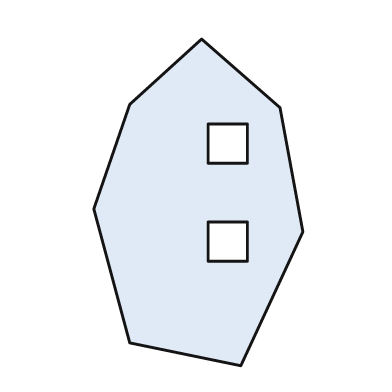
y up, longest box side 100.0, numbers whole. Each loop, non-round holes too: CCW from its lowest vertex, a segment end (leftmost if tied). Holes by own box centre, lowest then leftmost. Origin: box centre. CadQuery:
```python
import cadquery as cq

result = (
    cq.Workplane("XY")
    .moveTo(13.0, -50.0)
    .lineTo(32.0, -9.0)
    .lineTo(25.0, 29.0)
    .lineTo(1.0, 50.0)
    .lineTo(-21.0, 30.0)
    .lineTo(-32.0, -2.0)
    .lineTo(-21.0, -43.0)
    .close()
    .moveTo(3.0, -18.0)
    .lineTo(15.0, -18.0)
    .lineTo(15.0, -6.0)
    .lineTo(3.0, -6.0)
    .close()
    .moveTo(3.0, 12.0)
    .lineTo(15.0, 12.0)
    .lineTo(15.0, 24.0)
    .lineTo(3.0, 24.0)
    .close()
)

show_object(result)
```